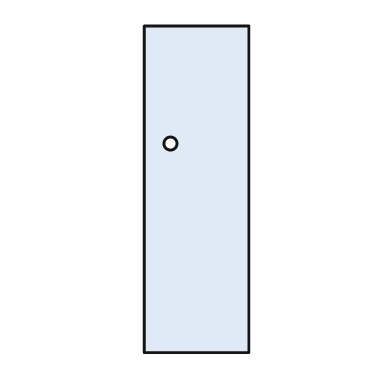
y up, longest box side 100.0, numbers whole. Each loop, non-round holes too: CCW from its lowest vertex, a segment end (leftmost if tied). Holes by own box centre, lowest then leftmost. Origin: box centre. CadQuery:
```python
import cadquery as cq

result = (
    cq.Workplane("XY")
    .moveTo(-16.0, -50.0)
    .lineTo(16.0, -50.0)
    .lineTo(16.0, 50.0)
    .lineTo(-16.0, 50.0)
    .close()
    .moveTo(-8.0, 14.0)
    .circle(2.0)
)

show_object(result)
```